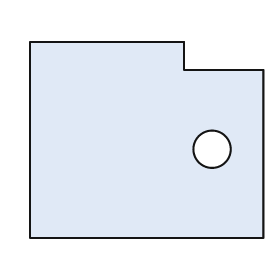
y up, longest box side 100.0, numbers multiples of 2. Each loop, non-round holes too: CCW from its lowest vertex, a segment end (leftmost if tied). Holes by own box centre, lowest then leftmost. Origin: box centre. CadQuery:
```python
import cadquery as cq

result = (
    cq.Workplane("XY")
    .moveTo(-50.0, -42.0)
    .lineTo(50.0, -42.0)
    .lineTo(50.0, 30.0)
    .lineTo(16.0, 30.0)
    .lineTo(16.0, 42.0)
    .lineTo(-50.0, 42.0)
    .close()
    .moveTo(28.0, -4.0)
    .circle(8.0)
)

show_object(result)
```